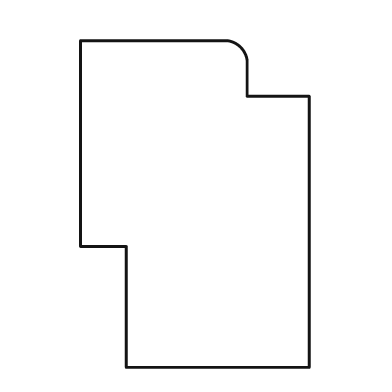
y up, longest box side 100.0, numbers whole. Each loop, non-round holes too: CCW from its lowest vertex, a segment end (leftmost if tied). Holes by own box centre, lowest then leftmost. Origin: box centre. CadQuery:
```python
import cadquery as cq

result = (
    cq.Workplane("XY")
    .moveTo(-21.0, -50.0)
    .lineTo(35.0, -50.0)
    .lineTo(35.0, 33.0)
    .lineTo(16.0, 33.0)
    .lineTo(16.0, 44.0)
    .threePointArc((14.0, 48.0), (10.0, 50.0))
    .lineTo(-35.0, 50.0)
    .lineTo(-35.0, -13.0)
    .lineTo(-21.0, -13.0)
    .close()
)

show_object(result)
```